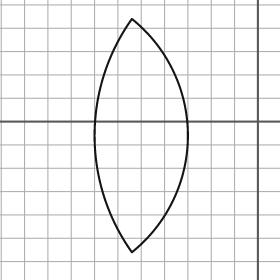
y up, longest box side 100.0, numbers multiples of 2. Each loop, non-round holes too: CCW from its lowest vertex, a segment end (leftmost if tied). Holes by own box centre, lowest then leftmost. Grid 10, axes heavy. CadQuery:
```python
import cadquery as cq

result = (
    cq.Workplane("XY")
    .moveTo(-54.0, -56.0)
    .threePointArc((-30.0, -6.0), (-54.0, 44.0))
    .threePointArc((-70.0, -6.0), (-54.0, -56.0))
    .close()
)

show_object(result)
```